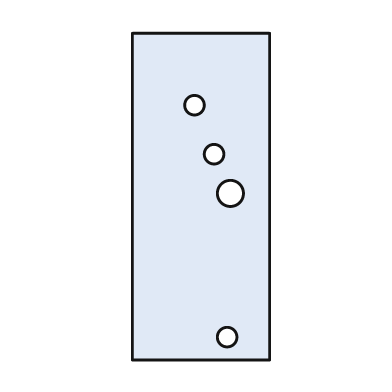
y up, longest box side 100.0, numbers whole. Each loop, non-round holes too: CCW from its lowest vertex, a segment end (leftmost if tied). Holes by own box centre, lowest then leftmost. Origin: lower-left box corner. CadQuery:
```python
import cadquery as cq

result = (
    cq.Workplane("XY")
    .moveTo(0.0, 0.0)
    .lineTo(42.0, 0.0)
    .lineTo(42.0, 100.0)
    .lineTo(0.0, 100.0)
    .close()
    .moveTo(29.0, 7.0)
    .circle(3.0)
    .moveTo(30.0, 51.0)
    .circle(4.0)
    .moveTo(25.0, 63.0)
    .circle(3.0)
    .moveTo(19.0, 78.0)
    .circle(3.0)
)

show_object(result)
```